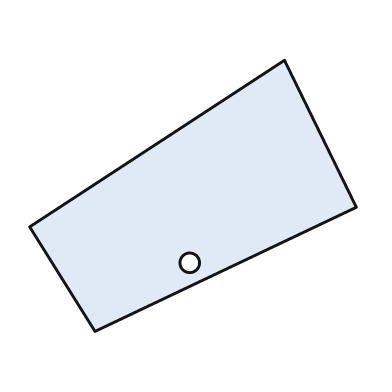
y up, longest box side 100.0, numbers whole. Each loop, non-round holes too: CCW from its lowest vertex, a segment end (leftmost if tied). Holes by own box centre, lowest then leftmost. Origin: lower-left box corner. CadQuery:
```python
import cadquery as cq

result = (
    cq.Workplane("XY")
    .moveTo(20.0, 0.0)
    .lineTo(100.0, 38.0)
    .lineTo(78.0, 83.0)
    .lineTo(0.0, 32.0)
    .close()
    .moveTo(49.0, 21.0)
    .circle(3.0)
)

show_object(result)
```